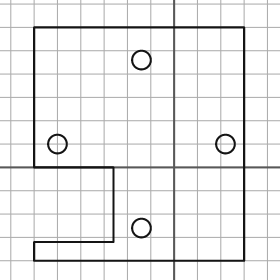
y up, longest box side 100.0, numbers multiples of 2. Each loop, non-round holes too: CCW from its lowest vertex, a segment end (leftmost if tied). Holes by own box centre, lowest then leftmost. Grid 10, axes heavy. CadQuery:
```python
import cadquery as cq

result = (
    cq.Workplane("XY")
    .moveTo(-60.0, -40.0)
    .lineTo(30.0, -40.0)
    .lineTo(30.0, 60.0)
    .lineTo(-60.0, 60.0)
    .lineTo(-60.0, 0.0)
    .lineTo(-26.0, 0.0)
    .lineTo(-26.0, -32.0)
    .lineTo(-60.0, -32.0)
    .close()
    .moveTo(-14.0, -26.0)
    .circle(4.0)
    .moveTo(-50.0, 10.0)
    .circle(4.0)
    .moveTo(22.0, 10.0)
    .circle(4.0)
    .moveTo(-14.0, 46.0)
    .circle(4.0)
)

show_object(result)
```